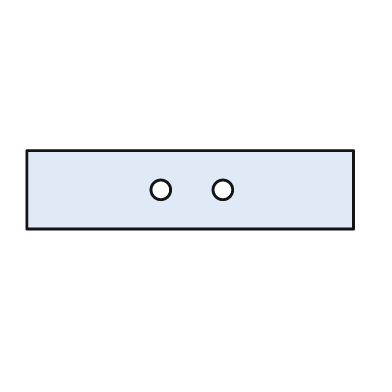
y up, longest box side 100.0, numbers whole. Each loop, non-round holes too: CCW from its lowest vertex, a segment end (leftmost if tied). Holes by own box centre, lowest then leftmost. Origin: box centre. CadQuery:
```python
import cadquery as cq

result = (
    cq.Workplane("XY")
    .moveTo(-50.0, -12.0)
    .lineTo(50.0, -12.0)
    .lineTo(50.0, 12.0)
    .lineTo(-50.0, 12.0)
    .close()
    .moveTo(-9.0, 0.0)
    .circle(3.0)
    .moveTo(10.0, 0.0)
    .circle(3.0)
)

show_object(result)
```